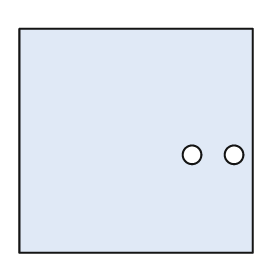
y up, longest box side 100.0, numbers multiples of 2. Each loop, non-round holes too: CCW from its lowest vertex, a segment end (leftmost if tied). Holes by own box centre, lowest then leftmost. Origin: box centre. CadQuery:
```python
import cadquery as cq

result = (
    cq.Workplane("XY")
    .moveTo(-50.0, -48.0)
    .lineTo(50.0, -48.0)
    .lineTo(50.0, 48.0)
    .lineTo(-50.0, 48.0)
    .close()
    .moveTo(24.0, -6.0)
    .circle(4.0)
    .moveTo(42.0, -6.0)
    .circle(4.0)
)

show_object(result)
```